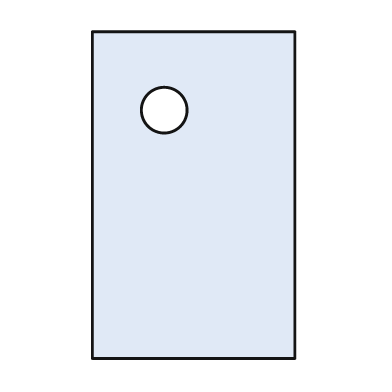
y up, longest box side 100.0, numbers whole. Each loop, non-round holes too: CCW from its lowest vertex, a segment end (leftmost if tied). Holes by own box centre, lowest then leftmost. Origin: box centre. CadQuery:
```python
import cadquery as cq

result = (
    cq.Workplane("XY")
    .moveTo(-31.0, -50.0)
    .lineTo(31.0, -50.0)
    .lineTo(31.0, 50.0)
    .lineTo(-31.0, 50.0)
    .close()
    .moveTo(-9.0, 26.0)
    .circle(7.0)
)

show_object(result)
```